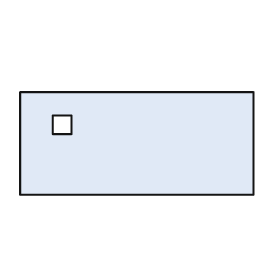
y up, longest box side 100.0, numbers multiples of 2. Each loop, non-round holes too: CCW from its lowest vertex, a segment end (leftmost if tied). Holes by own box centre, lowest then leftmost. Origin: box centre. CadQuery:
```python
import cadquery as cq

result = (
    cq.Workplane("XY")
    .moveTo(-50.0, -22.0)
    .lineTo(50.0, -22.0)
    .lineTo(50.0, 22.0)
    .lineTo(-50.0, 22.0)
    .close()
    .moveTo(-36.0, 4.0)
    .lineTo(-28.0, 4.0)
    .lineTo(-28.0, 12.0)
    .lineTo(-36.0, 12.0)
    .close()
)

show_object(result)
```